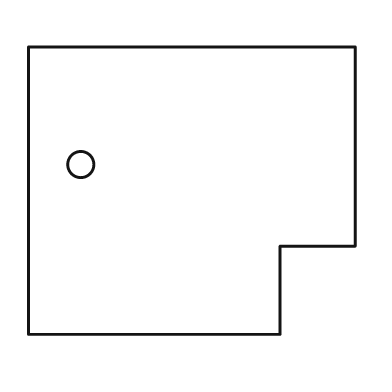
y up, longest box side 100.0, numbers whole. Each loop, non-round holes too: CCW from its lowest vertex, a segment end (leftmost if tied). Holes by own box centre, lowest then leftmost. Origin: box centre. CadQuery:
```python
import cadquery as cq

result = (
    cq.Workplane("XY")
    .moveTo(-50.0, -44.0)
    .lineTo(27.0, -44.0)
    .lineTo(27.0, -17.0)
    .lineTo(50.0, -17.0)
    .lineTo(50.0, 44.0)
    .lineTo(-50.0, 44.0)
    .close()
    .moveTo(-34.0, 8.0)
    .circle(4.0)
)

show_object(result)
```